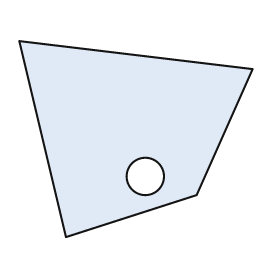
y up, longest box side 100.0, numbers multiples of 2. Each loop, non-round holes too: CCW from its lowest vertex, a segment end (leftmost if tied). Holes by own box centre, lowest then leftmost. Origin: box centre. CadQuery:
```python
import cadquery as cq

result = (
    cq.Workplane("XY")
    .moveTo(-30.0, -42.0)
    .lineTo(26.0, -24.0)
    .lineTo(50.0, 30.0)
    .lineTo(-50.0, 42.0)
    .close()
    .moveTo(4.0, -16.0)
    .circle(8.0)
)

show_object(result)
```